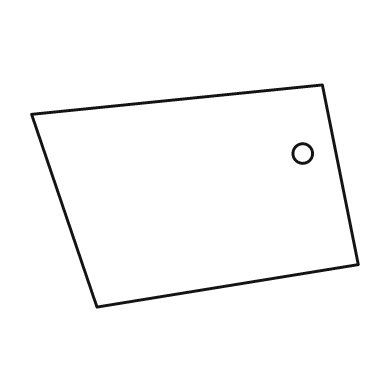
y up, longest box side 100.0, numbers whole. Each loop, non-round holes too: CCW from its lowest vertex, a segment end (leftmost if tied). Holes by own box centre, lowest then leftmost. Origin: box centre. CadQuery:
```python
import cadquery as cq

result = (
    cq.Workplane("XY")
    .moveTo(-30.0, -34.0)
    .lineTo(50.0, -21.0)
    .lineTo(39.0, 34.0)
    .lineTo(-50.0, 25.0)
    .close()
    .moveTo(33.0, 13.0)
    .circle(3.0)
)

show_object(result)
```